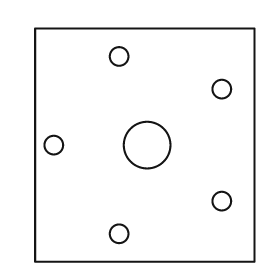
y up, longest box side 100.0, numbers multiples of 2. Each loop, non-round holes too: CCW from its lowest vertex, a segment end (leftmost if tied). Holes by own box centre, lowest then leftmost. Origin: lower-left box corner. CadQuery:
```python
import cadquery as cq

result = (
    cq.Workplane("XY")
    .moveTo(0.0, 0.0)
    .lineTo(94.0, 0.0)
    .lineTo(94.0, 100.0)
    .lineTo(0.0, 100.0)
    .close()
    .moveTo(36.0, 12.0)
    .circle(4.0)
    .moveTo(80.0, 26.0)
    .circle(4.0)
    .moveTo(8.0, 50.0)
    .circle(4.0)
    .moveTo(48.0, 50.0)
    .circle(10.0)
    .moveTo(80.0, 74.0)
    .circle(4.0)
    .moveTo(36.0, 88.0)
    .circle(4.0)
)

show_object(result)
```